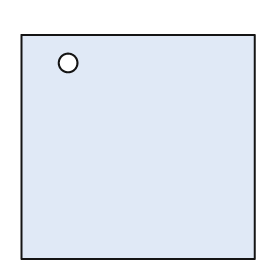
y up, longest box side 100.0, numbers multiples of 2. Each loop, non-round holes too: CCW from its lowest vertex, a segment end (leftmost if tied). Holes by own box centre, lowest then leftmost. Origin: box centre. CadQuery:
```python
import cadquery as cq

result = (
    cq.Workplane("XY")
    .moveTo(-50.0, -48.0)
    .lineTo(50.0, -48.0)
    .lineTo(50.0, 48.0)
    .lineTo(-50.0, 48.0)
    .close()
    .moveTo(-30.0, 36.0)
    .circle(4.0)
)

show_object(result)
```